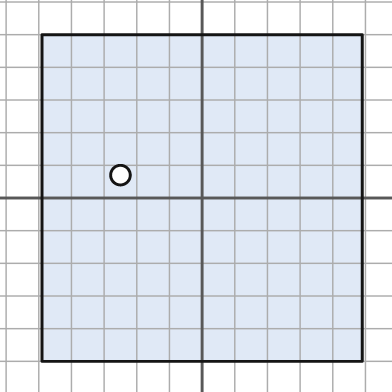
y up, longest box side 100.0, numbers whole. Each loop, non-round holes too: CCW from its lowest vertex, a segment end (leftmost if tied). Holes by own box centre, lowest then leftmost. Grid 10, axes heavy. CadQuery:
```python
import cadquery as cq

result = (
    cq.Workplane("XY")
    .moveTo(-49.0, -50.0)
    .lineTo(49.0, -50.0)
    .lineTo(49.0, 50.0)
    .lineTo(-49.0, 50.0)
    .close()
    .moveTo(-25.0, 7.0)
    .circle(3.0)
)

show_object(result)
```